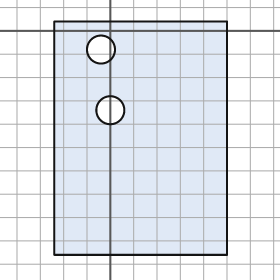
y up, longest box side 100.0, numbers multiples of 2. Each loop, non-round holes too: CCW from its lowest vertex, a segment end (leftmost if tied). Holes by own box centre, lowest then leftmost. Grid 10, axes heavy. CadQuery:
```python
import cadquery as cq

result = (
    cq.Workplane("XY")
    .moveTo(-24.0, -96.0)
    .lineTo(50.0, -96.0)
    .lineTo(50.0, 4.0)
    .lineTo(-24.0, 4.0)
    .close()
    .moveTo(0.0, -34.0)
    .circle(6.0)
    .moveTo(-4.0, -8.0)
    .circle(6.0)
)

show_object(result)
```